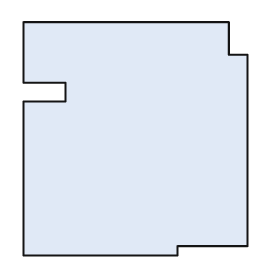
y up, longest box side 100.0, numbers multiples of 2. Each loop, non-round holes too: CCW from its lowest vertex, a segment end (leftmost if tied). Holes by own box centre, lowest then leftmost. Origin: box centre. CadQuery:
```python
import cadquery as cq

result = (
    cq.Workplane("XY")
    .moveTo(-48.0, -50.0)
    .lineTo(18.0, -50.0)
    .lineTo(18.0, -46.0)
    .lineTo(48.0, -46.0)
    .lineTo(48.0, 36.0)
    .lineTo(40.0, 36.0)
    .lineTo(40.0, 50.0)
    .lineTo(-48.0, 50.0)
    .lineTo(-48.0, 24.0)
    .lineTo(-30.0, 24.0)
    .lineTo(-30.0, 16.0)
    .lineTo(-48.0, 16.0)
    .close()
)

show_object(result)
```